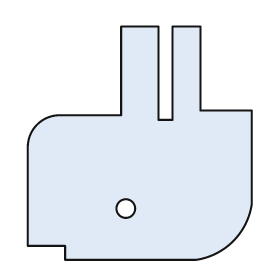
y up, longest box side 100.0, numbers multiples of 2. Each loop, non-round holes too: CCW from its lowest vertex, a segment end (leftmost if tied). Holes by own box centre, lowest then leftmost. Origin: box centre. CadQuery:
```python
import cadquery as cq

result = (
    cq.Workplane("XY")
    .moveTo(-32.0, -50.0)
    .lineTo(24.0, -50.0)
    .threePointArc((40.0, -42.0), (48.0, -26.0))
    .lineTo(48.0, 14.0)
    .lineTo(26.0, 14.0)
    .lineTo(26.0, 50.0)
    .lineTo(14.0, 50.0)
    .lineTo(14.0, 10.0)
    .lineTo(8.0, 10.0)
    .lineTo(8.0, 50.0)
    .lineTo(-8.0, 50.0)
    .lineTo(-8.0, 12.0)
    .lineTo(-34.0, 12.0)
    .threePointArc((-44.0, 8.0), (-48.0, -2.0))
    .lineTo(-48.0, -44.0)
    .lineTo(-32.0, -44.0)
    .close()
    .moveTo(-6.0, -28.0)
    .circle(4.0)
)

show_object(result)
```